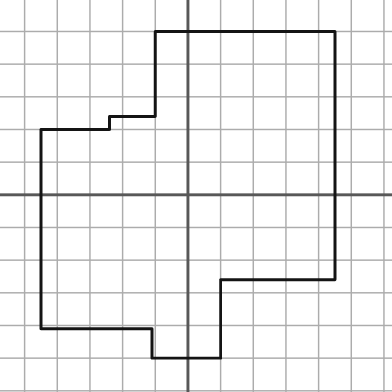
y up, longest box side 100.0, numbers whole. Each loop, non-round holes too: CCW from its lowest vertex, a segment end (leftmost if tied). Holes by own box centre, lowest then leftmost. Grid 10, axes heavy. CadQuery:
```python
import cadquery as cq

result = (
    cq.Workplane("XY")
    .moveTo(-11.0, -50.0)
    .lineTo(10.0, -50.0)
    .lineTo(10.0, -26.0)
    .lineTo(45.0, -26.0)
    .lineTo(45.0, 50.0)
    .lineTo(-10.0, 50.0)
    .lineTo(-10.0, 24.0)
    .lineTo(-24.0, 24.0)
    .lineTo(-24.0, 20.0)
    .lineTo(-45.0, 20.0)
    .lineTo(-45.0, -41.0)
    .lineTo(-11.0, -41.0)
    .close()
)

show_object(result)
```